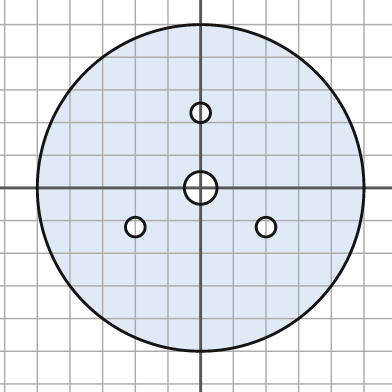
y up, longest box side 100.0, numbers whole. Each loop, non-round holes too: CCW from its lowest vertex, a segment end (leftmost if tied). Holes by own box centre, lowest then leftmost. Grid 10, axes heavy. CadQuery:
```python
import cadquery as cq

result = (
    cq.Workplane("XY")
    .moveTo(0.0, 0.0)
    .circle(50.0)
    .moveTo(-20.0, -12.0)
    .circle(3.0)
    .moveTo(20.0, -12.0)
    .circle(3.0)
    .moveTo(0.0, 0.0)
    .circle(5.0)
    .moveTo(0.0, 23.0)
    .circle(3.0)
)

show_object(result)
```